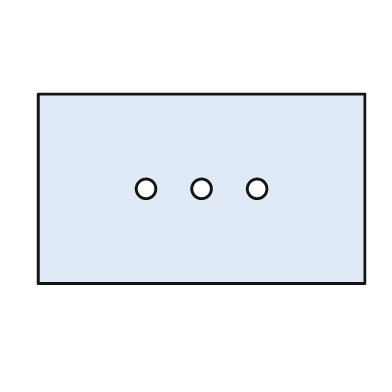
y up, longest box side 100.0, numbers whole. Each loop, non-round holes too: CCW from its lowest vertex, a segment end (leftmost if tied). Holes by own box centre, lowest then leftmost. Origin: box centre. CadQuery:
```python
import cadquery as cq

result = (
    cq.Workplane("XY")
    .moveTo(-50.0, -29.0)
    .lineTo(50.0, -29.0)
    .lineTo(50.0, 29.0)
    .lineTo(-50.0, 29.0)
    .close()
    .moveTo(-17.0, 0.0)
    .circle(3.0)
    .moveTo(0.0, 0.0)
    .circle(3.0)
    .moveTo(17.0, 0.0)
    .circle(3.0)
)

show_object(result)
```